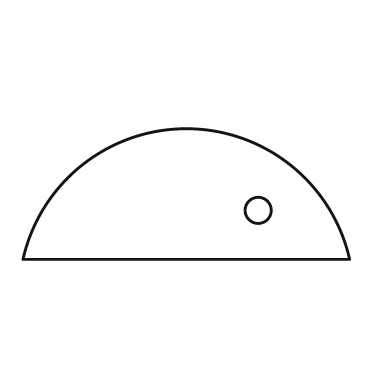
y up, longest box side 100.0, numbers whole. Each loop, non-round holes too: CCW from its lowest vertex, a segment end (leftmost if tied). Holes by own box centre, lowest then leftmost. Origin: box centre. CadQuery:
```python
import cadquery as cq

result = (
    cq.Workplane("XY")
    .moveTo(-50.0, -20.0)
    .lineTo(50.0, -20.0)
    .threePointArc((0.0, 20.0), (-50.0, -20.0))
    .close()
    .moveTo(22.0, -5.0)
    .circle(4.0)
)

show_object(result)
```